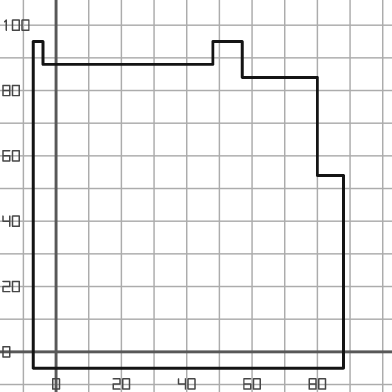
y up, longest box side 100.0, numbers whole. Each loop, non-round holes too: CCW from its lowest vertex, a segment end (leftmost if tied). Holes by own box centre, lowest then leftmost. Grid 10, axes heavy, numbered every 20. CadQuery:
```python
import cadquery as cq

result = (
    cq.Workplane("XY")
    .moveTo(-7.0, -5.0)
    .lineTo(88.0, -5.0)
    .lineTo(88.0, 54.0)
    .lineTo(80.0, 54.0)
    .lineTo(80.0, 84.0)
    .lineTo(57.0, 84.0)
    .lineTo(57.0, 95.0)
    .lineTo(48.0, 95.0)
    .lineTo(48.0, 88.0)
    .lineTo(-4.0, 88.0)
    .lineTo(-4.0, 95.0)
    .lineTo(-7.0, 95.0)
    .close()
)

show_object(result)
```